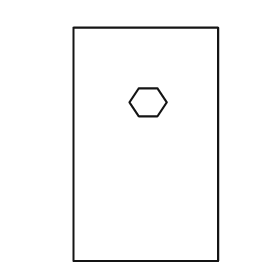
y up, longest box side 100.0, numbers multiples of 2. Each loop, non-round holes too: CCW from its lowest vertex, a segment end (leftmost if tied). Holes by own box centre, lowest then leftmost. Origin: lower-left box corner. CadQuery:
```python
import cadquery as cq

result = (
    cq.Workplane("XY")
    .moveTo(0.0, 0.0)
    .lineTo(62.0, 0.0)
    .lineTo(62.0, 100.0)
    .lineTo(0.0, 100.0)
    .close()
    .moveTo(28.0, 62.0)
    .lineTo(36.0, 62.0)
    .lineTo(40.0, 68.0)
    .lineTo(36.0, 74.0)
    .lineTo(28.0, 74.0)
    .lineTo(24.0, 68.0)
    .close()
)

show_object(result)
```